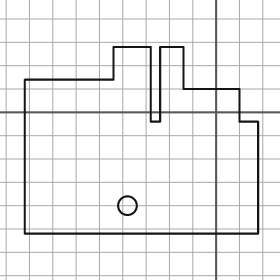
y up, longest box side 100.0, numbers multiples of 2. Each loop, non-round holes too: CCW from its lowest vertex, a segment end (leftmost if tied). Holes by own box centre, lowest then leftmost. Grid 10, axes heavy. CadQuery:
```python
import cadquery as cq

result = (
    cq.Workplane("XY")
    .moveTo(-82.0, -52.0)
    .lineTo(18.0, -52.0)
    .lineTo(18.0, -4.0)
    .lineTo(10.0, -4.0)
    .lineTo(10.0, 10.0)
    .lineTo(-14.0, 10.0)
    .lineTo(-14.0, 28.0)
    .lineTo(-24.0, 28.0)
    .lineTo(-24.0, -4.0)
    .lineTo(-28.0, -4.0)
    .lineTo(-28.0, 28.0)
    .lineTo(-44.0, 28.0)
    .lineTo(-44.0, 14.0)
    .lineTo(-82.0, 14.0)
    .close()
    .moveTo(-38.0, -40.0)
    .circle(4.0)
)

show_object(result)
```